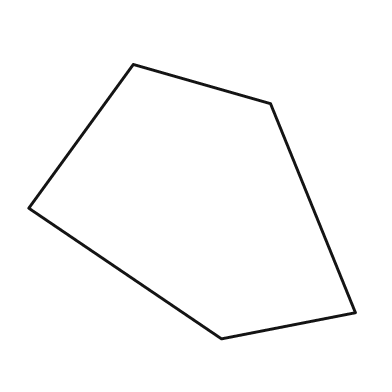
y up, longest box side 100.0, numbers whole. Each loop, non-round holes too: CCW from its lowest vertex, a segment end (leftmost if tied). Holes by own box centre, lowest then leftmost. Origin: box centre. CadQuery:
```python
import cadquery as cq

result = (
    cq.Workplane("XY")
    .moveTo(9.0, -42.0)
    .lineTo(50.0, -34.0)
    .lineTo(24.0, 30.0)
    .lineTo(-18.0, 42.0)
    .lineTo(-50.0, -2.0)
    .close()
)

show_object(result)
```